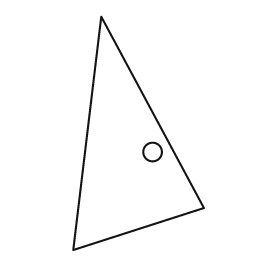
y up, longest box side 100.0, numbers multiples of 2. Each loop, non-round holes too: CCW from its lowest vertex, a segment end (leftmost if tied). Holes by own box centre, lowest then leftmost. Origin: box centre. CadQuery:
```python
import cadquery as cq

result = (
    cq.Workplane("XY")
    .moveTo(-28.0, -50.0)
    .lineTo(28.0, -32.0)
    .lineTo(-16.0, 50.0)
    .close()
    .moveTo(6.0, -8.0)
    .circle(4.0)
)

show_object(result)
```